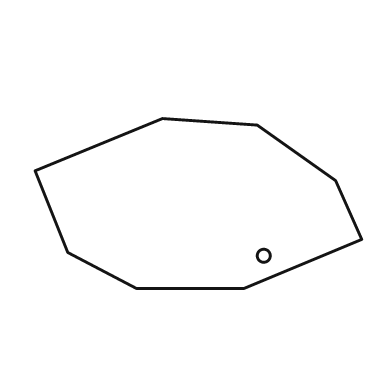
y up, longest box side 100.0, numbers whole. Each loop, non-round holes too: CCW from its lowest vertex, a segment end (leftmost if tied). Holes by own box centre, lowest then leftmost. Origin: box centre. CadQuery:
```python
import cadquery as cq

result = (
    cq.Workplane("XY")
    .moveTo(-19.0, -26.0)
    .lineTo(14.0, -26.0)
    .lineTo(50.0, -11.0)
    .lineTo(42.0, 7.0)
    .lineTo(18.0, 24.0)
    .lineTo(-11.0, 26.0)
    .lineTo(-50.0, 10.0)
    .lineTo(-40.0, -15.0)
    .close()
    .moveTo(20.0, -16.0)
    .circle(2.0)
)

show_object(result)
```